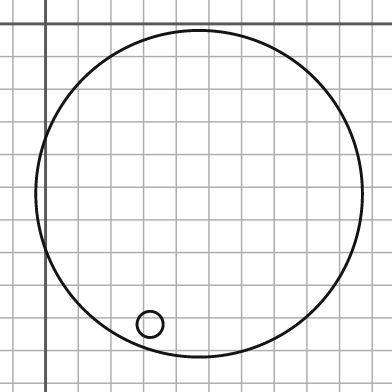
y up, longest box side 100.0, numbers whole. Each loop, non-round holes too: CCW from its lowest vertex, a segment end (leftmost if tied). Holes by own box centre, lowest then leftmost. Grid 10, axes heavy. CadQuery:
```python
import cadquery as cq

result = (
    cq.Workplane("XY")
    .moveTo(47.0, -52.0)
    .circle(50.0)
    .moveTo(32.0, -92.0)
    .circle(4.0)
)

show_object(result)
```